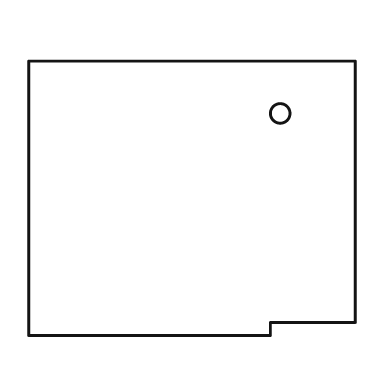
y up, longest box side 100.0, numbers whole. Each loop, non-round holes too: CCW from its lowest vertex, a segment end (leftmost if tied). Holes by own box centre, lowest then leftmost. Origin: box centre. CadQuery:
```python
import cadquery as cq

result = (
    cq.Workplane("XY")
    .moveTo(-50.0, -42.0)
    .lineTo(24.0, -42.0)
    .lineTo(24.0, -38.0)
    .lineTo(50.0, -38.0)
    .lineTo(50.0, 42.0)
    .lineTo(-50.0, 42.0)
    .close()
    .moveTo(27.0, 26.0)
    .circle(3.0)
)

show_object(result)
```